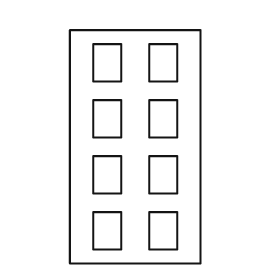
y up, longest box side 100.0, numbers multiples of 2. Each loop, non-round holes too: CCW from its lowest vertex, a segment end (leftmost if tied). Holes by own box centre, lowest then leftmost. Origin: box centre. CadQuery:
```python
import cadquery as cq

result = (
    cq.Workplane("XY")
    .moveTo(-28.0, -50.0)
    .lineTo(28.0, -50.0)
    .lineTo(28.0, 50.0)
    .lineTo(-28.0, 50.0)
    .close()
    .moveTo(-18.0, -44.0)
    .lineTo(-6.0, -44.0)
    .lineTo(-6.0, -28.0)
    .lineTo(-18.0, -28.0)
    .close()
    .moveTo(6.0, -44.0)
    .lineTo(18.0, -44.0)
    .lineTo(18.0, -28.0)
    .lineTo(6.0, -28.0)
    .close()
    .moveTo(-18.0, -20.0)
    .lineTo(-6.0, -20.0)
    .lineTo(-6.0, -4.0)
    .lineTo(-18.0, -4.0)
    .close()
    .moveTo(6.0, -20.0)
    .lineTo(18.0, -20.0)
    .lineTo(18.0, -4.0)
    .lineTo(6.0, -4.0)
    .close()
    .moveTo(-18.0, 4.0)
    .lineTo(-6.0, 4.0)
    .lineTo(-6.0, 20.0)
    .lineTo(-18.0, 20.0)
    .close()
    .moveTo(6.0, 4.0)
    .lineTo(18.0, 4.0)
    .lineTo(18.0, 20.0)
    .lineTo(6.0, 20.0)
    .close()
    .moveTo(-18.0, 28.0)
    .lineTo(-6.0, 28.0)
    .lineTo(-6.0, 44.0)
    .lineTo(-18.0, 44.0)
    .close()
    .moveTo(6.0, 28.0)
    .lineTo(18.0, 28.0)
    .lineTo(18.0, 44.0)
    .lineTo(6.0, 44.0)
    .close()
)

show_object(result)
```